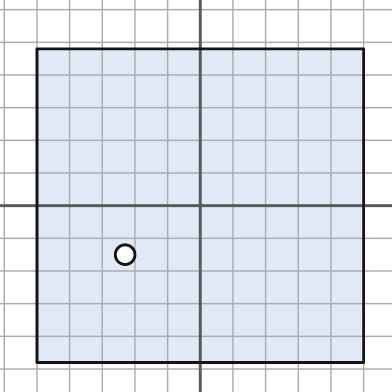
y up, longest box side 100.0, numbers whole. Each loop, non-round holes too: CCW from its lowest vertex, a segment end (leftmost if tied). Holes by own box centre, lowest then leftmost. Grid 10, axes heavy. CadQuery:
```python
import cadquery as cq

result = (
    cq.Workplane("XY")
    .moveTo(-50.0, -48.0)
    .lineTo(50.0, -48.0)
    .lineTo(50.0, 48.0)
    .lineTo(-50.0, 48.0)
    .close()
    .moveTo(-23.0, -15.0)
    .circle(3.0)
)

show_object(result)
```